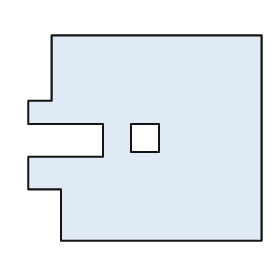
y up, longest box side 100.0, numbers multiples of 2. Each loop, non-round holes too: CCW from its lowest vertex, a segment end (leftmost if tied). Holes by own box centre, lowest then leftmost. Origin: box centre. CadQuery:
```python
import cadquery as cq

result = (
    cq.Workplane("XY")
    .moveTo(-36.0, -44.0)
    .lineTo(50.0, -44.0)
    .lineTo(50.0, 44.0)
    .lineTo(-40.0, 44.0)
    .lineTo(-40.0, 16.0)
    .lineTo(-50.0, 16.0)
    .lineTo(-50.0, 6.0)
    .lineTo(-18.0, 6.0)
    .lineTo(-18.0, -8.0)
    .lineTo(-50.0, -8.0)
    .lineTo(-50.0, -22.0)
    .lineTo(-36.0, -22.0)
    .close()
    .moveTo(-6.0, -6.0)
    .lineTo(6.0, -6.0)
    .lineTo(6.0, 6.0)
    .lineTo(-6.0, 6.0)
    .close()
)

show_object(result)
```